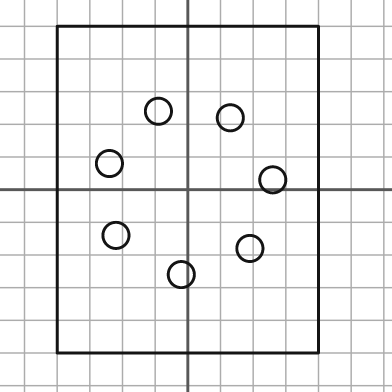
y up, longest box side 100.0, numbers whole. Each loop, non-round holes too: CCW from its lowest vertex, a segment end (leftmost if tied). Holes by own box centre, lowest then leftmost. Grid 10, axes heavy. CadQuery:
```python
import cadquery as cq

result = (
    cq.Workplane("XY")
    .moveTo(-40.0, -50.0)
    .lineTo(40.0, -50.0)
    .lineTo(40.0, 50.0)
    .lineTo(-40.0, 50.0)
    .close()
    .moveTo(-2.0, -26.0)
    .circle(4.0)
    .moveTo(19.0, -18.0)
    .circle(4.0)
    .moveTo(-22.0, -14.0)
    .circle(4.0)
    .moveTo(26.0, 3.0)
    .circle(4.0)
    .moveTo(-24.0, 8.0)
    .circle(4.0)
    .moveTo(13.0, 22.0)
    .circle(4.0)
    .moveTo(-9.0, 24.0)
    .circle(4.0)
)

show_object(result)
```